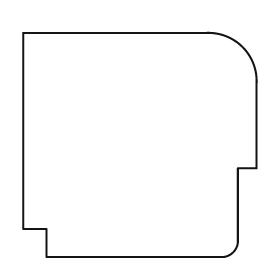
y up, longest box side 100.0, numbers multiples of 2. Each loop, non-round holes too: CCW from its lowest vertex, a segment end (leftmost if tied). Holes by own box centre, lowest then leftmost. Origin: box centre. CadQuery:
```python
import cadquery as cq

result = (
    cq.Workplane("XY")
    .moveTo(-40.0, -48.0)
    .lineTo(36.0, -48.0)
    .threePointArc((40.0, -46.0), (42.0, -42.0))
    .lineTo(42.0, -10.0)
    .lineTo(50.0, -10.0)
    .lineTo(50.0, 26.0)
    .threePointArc((44.0, 42.0), (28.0, 48.0))
    .lineTo(-50.0, 48.0)
    .lineTo(-50.0, -36.0)
    .lineTo(-40.0, -36.0)
    .close()
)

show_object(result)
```